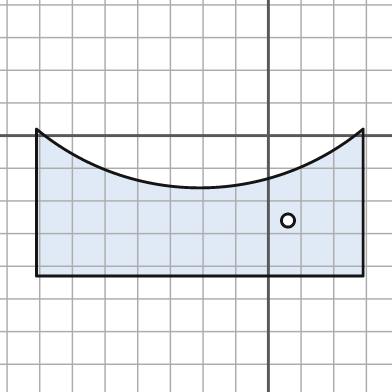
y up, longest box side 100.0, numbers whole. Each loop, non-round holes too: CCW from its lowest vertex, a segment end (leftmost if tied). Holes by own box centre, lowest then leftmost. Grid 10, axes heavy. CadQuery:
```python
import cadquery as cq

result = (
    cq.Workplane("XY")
    .moveTo(-71.0, -43.0)
    .lineTo(29.0, -43.0)
    .lineTo(29.0, 2.0)
    .threePointArc((-21.0, -16.0), (-71.0, 2.0))
    .close()
    .moveTo(6.0, -26.0)
    .circle(2.0)
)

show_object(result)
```